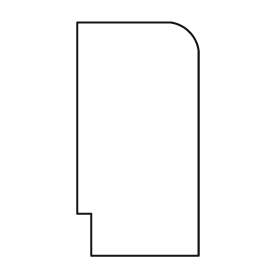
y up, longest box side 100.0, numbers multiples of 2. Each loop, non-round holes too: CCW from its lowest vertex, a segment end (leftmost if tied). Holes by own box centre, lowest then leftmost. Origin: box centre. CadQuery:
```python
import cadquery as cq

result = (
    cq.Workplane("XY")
    .moveTo(-20.0, -50.0)
    .lineTo(26.0, -50.0)
    .lineTo(26.0, 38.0)
    .threePointArc((22.0, 46.0), (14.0, 50.0))
    .lineTo(-26.0, 50.0)
    .lineTo(-26.0, -32.0)
    .lineTo(-20.0, -32.0)
    .close()
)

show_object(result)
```